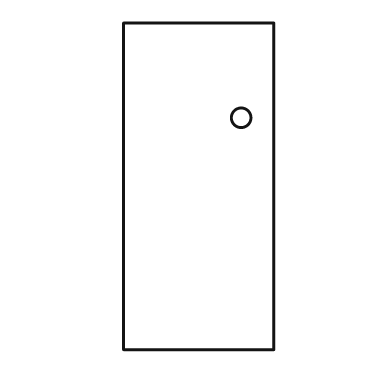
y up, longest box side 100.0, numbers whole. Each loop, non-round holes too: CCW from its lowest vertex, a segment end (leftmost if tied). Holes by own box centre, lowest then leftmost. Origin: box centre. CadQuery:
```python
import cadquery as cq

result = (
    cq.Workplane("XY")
    .moveTo(-23.0, -50.0)
    .lineTo(23.0, -50.0)
    .lineTo(23.0, 50.0)
    .lineTo(-23.0, 50.0)
    .close()
    .moveTo(13.0, 21.0)
    .circle(3.0)
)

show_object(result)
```